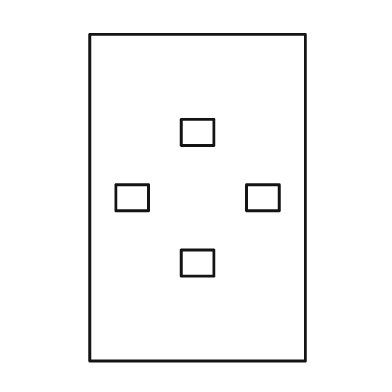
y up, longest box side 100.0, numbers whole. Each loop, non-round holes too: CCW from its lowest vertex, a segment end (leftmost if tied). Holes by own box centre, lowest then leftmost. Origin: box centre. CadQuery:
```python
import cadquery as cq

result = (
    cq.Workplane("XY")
    .moveTo(-33.0, -50.0)
    .lineTo(33.0, -50.0)
    .lineTo(33.0, 50.0)
    .lineTo(-33.0, 50.0)
    .close()
    .moveTo(-5.0, -24.0)
    .lineTo(5.0, -24.0)
    .lineTo(5.0, -16.0)
    .lineTo(-5.0, -16.0)
    .close()
    .moveTo(-25.0, -4.0)
    .lineTo(-15.0, -4.0)
    .lineTo(-15.0, 4.0)
    .lineTo(-25.0, 4.0)
    .close()
    .moveTo(15.0, -4.0)
    .lineTo(25.0, -4.0)
    .lineTo(25.0, 4.0)
    .lineTo(15.0, 4.0)
    .close()
    .moveTo(-5.0, 16.0)
    .lineTo(5.0, 16.0)
    .lineTo(5.0, 24.0)
    .lineTo(-5.0, 24.0)
    .close()
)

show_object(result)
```